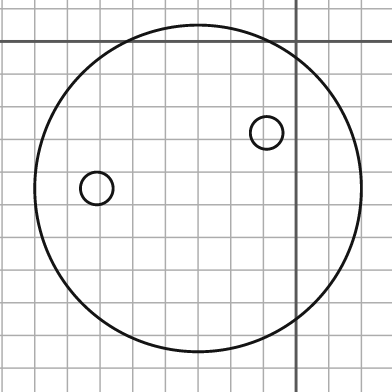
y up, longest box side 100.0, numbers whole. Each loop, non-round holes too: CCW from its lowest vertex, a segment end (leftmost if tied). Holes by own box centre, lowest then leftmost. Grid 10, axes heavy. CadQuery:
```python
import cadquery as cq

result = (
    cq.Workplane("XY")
    .moveTo(-30.0, -45.0)
    .circle(50.0)
    .moveTo(-61.0, -45.0)
    .circle(5.0)
    .moveTo(-9.0, -28.0)
    .circle(5.0)
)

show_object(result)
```